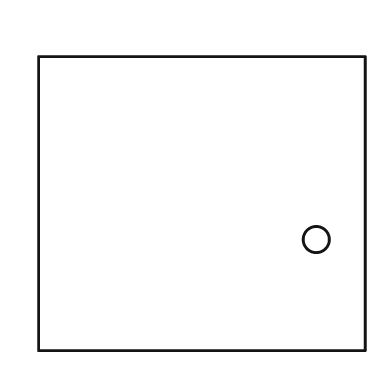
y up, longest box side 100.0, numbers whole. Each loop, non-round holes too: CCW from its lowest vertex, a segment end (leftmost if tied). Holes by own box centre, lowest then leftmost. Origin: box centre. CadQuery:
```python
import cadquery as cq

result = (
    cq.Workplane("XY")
    .moveTo(-50.0, -45.0)
    .lineTo(50.0, -45.0)
    .lineTo(50.0, 45.0)
    .lineTo(-50.0, 45.0)
    .close()
    .moveTo(35.0, -11.0)
    .circle(4.0)
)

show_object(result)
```